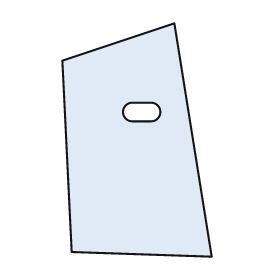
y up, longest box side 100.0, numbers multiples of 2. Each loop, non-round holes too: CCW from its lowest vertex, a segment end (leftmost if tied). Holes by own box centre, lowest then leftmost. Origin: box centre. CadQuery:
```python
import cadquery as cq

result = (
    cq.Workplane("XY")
    .moveTo(32.0, -50.0)
    .lineTo(16.0, 50.0)
    .lineTo(-32.0, 34.0)
    .lineTo(-28.0, -48.0)
    .close()
    .moveTo(-2.0, 8.0)
    .lineTo(6.0, 8.0)
    .threePointArc((10.0, 12.0), (6.0, 16.0))
    .lineTo(-2.0, 16.0)
    .threePointArc((-6.0, 12.0), (-2.0, 8.0))
    .close()
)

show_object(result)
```